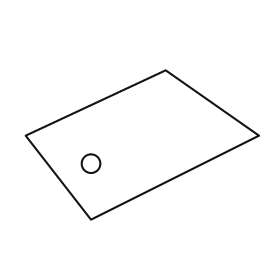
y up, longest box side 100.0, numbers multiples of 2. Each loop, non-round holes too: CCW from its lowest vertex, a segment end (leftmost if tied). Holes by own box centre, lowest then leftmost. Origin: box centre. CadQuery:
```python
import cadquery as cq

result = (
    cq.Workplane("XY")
    .moveTo(-22.0, -32.0)
    .lineTo(50.0, 4.0)
    .lineTo(10.0, 32.0)
    .lineTo(-50.0, 4.0)
    .close()
    .moveTo(-22.0, -8.0)
    .circle(4.0)
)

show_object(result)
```